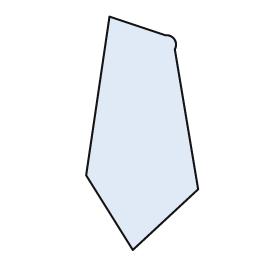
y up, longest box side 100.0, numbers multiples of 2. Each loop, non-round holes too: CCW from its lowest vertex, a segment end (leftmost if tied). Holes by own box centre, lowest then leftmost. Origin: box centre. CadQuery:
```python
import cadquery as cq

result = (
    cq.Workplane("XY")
    .moveTo(-4.0, -50.0)
    .lineTo(24.0, -24.0)
    .lineTo(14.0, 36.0)
    .threePointArc((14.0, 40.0), (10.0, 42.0))
    .lineTo(-14.0, 50.0)
    .lineTo(-24.0, -18.0)
    .close()
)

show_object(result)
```